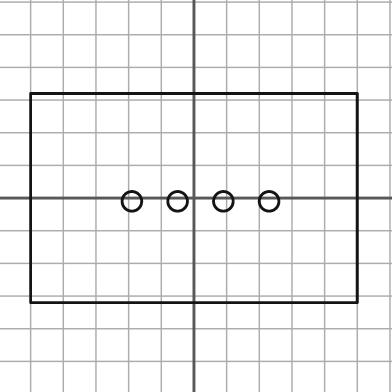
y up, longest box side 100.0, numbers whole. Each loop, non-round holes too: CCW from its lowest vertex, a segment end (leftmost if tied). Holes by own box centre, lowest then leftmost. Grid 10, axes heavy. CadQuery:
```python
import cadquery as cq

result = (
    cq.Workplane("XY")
    .moveTo(-50.0, -32.0)
    .lineTo(50.0, -32.0)
    .lineTo(50.0, 32.0)
    .lineTo(-50.0, 32.0)
    .close()
    .moveTo(-19.0, -1.0)
    .circle(3.0)
    .moveTo(-5.0, -1.0)
    .circle(3.0)
    .moveTo(9.0, -1.0)
    .circle(3.0)
    .moveTo(23.0, -1.0)
    .circle(3.0)
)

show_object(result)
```